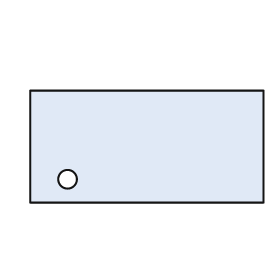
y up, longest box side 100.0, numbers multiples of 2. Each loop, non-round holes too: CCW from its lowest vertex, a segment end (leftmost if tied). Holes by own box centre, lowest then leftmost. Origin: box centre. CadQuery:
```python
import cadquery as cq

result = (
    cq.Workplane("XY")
    .moveTo(-50.0, -24.0)
    .lineTo(50.0, -24.0)
    .lineTo(50.0, 24.0)
    .lineTo(-50.0, 24.0)
    .close()
    .moveTo(-34.0, -14.0)
    .circle(4.0)
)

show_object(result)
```